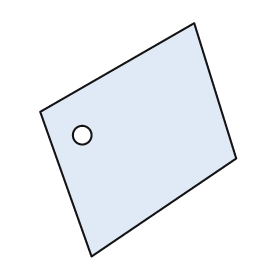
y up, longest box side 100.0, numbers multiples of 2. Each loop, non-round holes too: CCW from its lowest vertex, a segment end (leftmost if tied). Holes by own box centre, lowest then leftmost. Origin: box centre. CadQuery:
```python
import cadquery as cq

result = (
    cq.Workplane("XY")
    .moveTo(-20.0, -50.0)
    .lineTo(42.0, -8.0)
    .lineTo(24.0, 50.0)
    .lineTo(-42.0, 12.0)
    .close()
    .moveTo(-24.0, 2.0)
    .circle(4.0)
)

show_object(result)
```